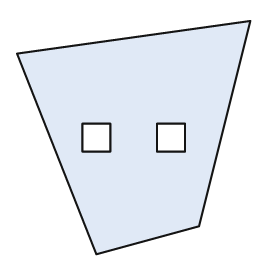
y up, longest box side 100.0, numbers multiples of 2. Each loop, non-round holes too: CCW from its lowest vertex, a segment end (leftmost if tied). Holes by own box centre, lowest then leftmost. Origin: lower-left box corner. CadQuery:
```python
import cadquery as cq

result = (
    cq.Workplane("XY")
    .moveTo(34.0, 0.0)
    .lineTo(78.0, 12.0)
    .lineTo(100.0, 100.0)
    .lineTo(0.0, 86.0)
    .close()
    .moveTo(28.0, 44.0)
    .lineTo(40.0, 44.0)
    .lineTo(40.0, 56.0)
    .lineTo(28.0, 56.0)
    .close()
    .moveTo(60.0, 44.0)
    .lineTo(72.0, 44.0)
    .lineTo(72.0, 56.0)
    .lineTo(60.0, 56.0)
    .close()
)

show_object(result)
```